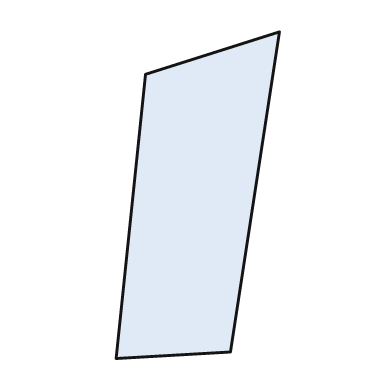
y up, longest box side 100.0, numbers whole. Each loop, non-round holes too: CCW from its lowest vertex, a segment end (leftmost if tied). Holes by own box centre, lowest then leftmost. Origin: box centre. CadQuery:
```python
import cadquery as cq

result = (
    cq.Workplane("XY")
    .moveTo(-25.0, -50.0)
    .lineTo(10.0, -48.0)
    .lineTo(25.0, 50.0)
    .lineTo(-16.0, 37.0)
    .close()
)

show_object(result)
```